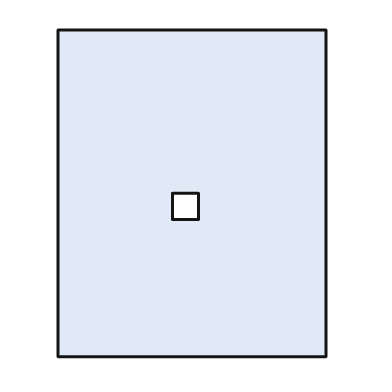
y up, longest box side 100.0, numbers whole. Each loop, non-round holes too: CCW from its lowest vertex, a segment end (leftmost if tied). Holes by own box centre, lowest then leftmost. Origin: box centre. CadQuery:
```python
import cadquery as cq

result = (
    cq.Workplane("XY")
    .moveTo(-41.0, -50.0)
    .lineTo(41.0, -50.0)
    .lineTo(41.0, 50.0)
    .lineTo(-41.0, 50.0)
    .close()
    .moveTo(-6.0, -8.0)
    .lineTo(2.0, -8.0)
    .lineTo(2.0, 0.0)
    .lineTo(-6.0, 0.0)
    .close()
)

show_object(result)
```